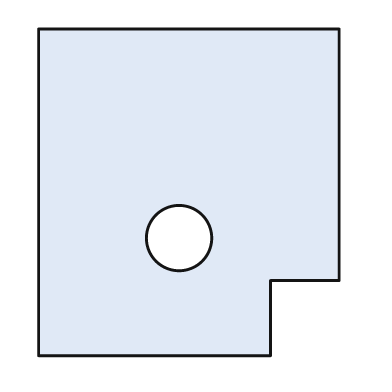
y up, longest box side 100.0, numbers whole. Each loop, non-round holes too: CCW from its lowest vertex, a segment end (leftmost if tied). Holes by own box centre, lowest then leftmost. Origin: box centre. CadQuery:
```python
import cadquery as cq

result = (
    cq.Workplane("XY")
    .moveTo(-46.0, -50.0)
    .lineTo(25.0, -50.0)
    .lineTo(25.0, -27.0)
    .lineTo(46.0, -27.0)
    .lineTo(46.0, 50.0)
    .lineTo(-46.0, 50.0)
    .close()
    .moveTo(-3.0, -14.0)
    .circle(10.0)
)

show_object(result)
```